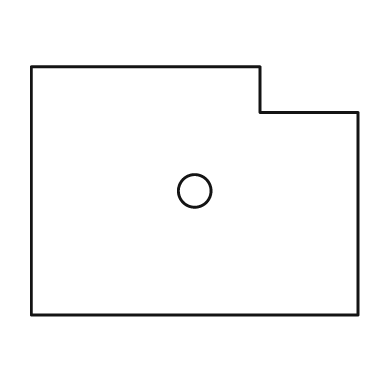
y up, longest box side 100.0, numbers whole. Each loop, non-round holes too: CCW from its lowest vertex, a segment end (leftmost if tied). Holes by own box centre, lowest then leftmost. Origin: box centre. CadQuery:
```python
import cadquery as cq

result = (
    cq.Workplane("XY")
    .moveTo(-50.0, -38.0)
    .lineTo(50.0, -38.0)
    .lineTo(50.0, 24.0)
    .lineTo(20.0, 24.0)
    .lineTo(20.0, 38.0)
    .lineTo(-50.0, 38.0)
    .close()
    .moveTo(0.0, 0.0)
    .circle(5.0)
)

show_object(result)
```